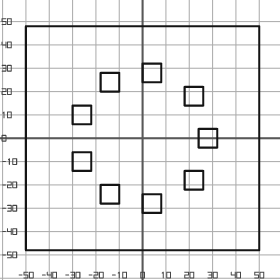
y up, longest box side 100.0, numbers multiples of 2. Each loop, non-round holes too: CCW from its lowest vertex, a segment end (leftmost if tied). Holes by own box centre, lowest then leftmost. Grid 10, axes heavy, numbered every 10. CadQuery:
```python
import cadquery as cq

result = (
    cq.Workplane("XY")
    .moveTo(-50.0, -48.0)
    .lineTo(50.0, -48.0)
    .lineTo(50.0, 48.0)
    .lineTo(-50.0, 48.0)
    .close()
    .moveTo(0.0, -32.0)
    .lineTo(8.0, -32.0)
    .lineTo(8.0, -24.0)
    .lineTo(0.0, -24.0)
    .close()
    .moveTo(-18.0, -28.0)
    .lineTo(-10.0, -28.0)
    .lineTo(-10.0, -20.0)
    .lineTo(-18.0, -20.0)
    .close()
    .moveTo(18.0, -22.0)
    .lineTo(26.0, -22.0)
    .lineTo(26.0, -14.0)
    .lineTo(18.0, -14.0)
    .close()
    .moveTo(-30.0, -14.0)
    .lineTo(-22.0, -14.0)
    .lineTo(-22.0, -6.0)
    .lineTo(-30.0, -6.0)
    .close()
    .moveTo(24.0, -4.0)
    .lineTo(32.0, -4.0)
    .lineTo(32.0, 4.0)
    .lineTo(24.0, 4.0)
    .close()
    .moveTo(-30.0, 6.0)
    .lineTo(-22.0, 6.0)
    .lineTo(-22.0, 14.0)
    .lineTo(-30.0, 14.0)
    .close()
    .moveTo(18.0, 14.0)
    .lineTo(26.0, 14.0)
    .lineTo(26.0, 22.0)
    .lineTo(18.0, 22.0)
    .close()
    .moveTo(-18.0, 20.0)
    .lineTo(-10.0, 20.0)
    .lineTo(-10.0, 28.0)
    .lineTo(-18.0, 28.0)
    .close()
    .moveTo(0.0, 24.0)
    .lineTo(8.0, 24.0)
    .lineTo(8.0, 32.0)
    .lineTo(0.0, 32.0)
    .close()
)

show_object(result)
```